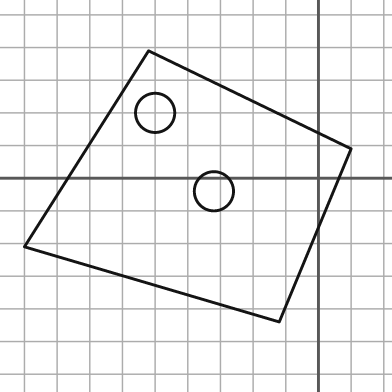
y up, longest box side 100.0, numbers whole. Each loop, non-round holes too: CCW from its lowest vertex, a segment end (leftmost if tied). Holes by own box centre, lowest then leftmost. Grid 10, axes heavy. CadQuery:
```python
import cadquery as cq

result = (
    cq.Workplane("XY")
    .moveTo(-12.0, -44.0)
    .lineTo(10.0, 9.0)
    .lineTo(-52.0, 39.0)
    .lineTo(-90.0, -21.0)
    .close()
    .moveTo(-32.0, -4.0)
    .circle(6.0)
    .moveTo(-50.0, 20.0)
    .circle(6.0)
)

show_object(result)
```